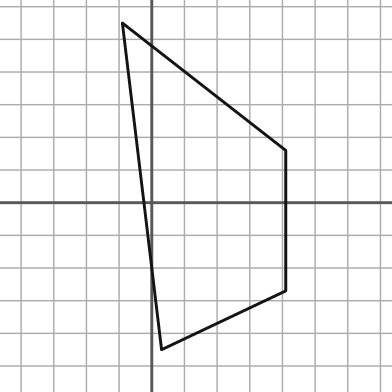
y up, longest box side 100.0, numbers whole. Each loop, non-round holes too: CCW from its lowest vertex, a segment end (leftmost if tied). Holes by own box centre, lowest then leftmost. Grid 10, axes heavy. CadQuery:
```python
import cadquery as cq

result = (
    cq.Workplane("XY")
    .moveTo(3.0, -45.0)
    .lineTo(41.0, -27.0)
    .lineTo(41.0, 16.0)
    .lineTo(-9.0, 55.0)
    .close()
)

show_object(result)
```